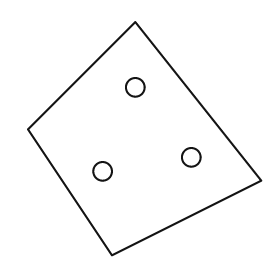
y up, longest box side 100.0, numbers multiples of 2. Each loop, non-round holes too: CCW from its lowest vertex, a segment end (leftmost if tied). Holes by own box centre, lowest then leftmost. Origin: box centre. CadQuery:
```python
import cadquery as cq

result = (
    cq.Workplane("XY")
    .moveTo(-14.0, -50.0)
    .lineTo(50.0, -18.0)
    .lineTo(-4.0, 50.0)
    .lineTo(-50.0, 4.0)
    .close()
    .moveTo(-18.0, -14.0)
    .circle(4.0)
    .moveTo(20.0, -8.0)
    .circle(4.0)
    .moveTo(-4.0, 22.0)
    .circle(4.0)
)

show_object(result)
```